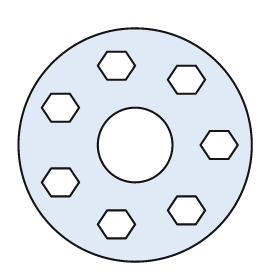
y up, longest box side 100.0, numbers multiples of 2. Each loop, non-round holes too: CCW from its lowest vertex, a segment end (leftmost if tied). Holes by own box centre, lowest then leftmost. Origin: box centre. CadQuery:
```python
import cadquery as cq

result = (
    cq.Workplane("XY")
    .moveTo(0.0, 0.0)
    .circle(50.0)
    .moveTo(-12.0, -40.0)
    .lineTo(-4.0, -40.0)
    .lineTo(0.0, -34.0)
    .lineTo(-4.0, -28.0)
    .lineTo(-12.0, -28.0)
    .lineTo(-16.0, -34.0)
    .close()
    .moveTo(18.0, -34.0)
    .lineTo(26.0, -34.0)
    .lineTo(30.0, -28.0)
    .lineTo(26.0, -22.0)
    .lineTo(18.0, -22.0)
    .lineTo(14.0, -28.0)
    .close()
    .moveTo(-36.0, -22.0)
    .lineTo(-28.0, -22.0)
    .lineTo(-24.0, -16.0)
    .lineTo(-28.0, -10.0)
    .lineTo(-36.0, -10.0)
    .lineTo(-40.0, -16.0)
    .close()
    .moveTo(0.0, 0.0)
    .circle(16.0)
    .moveTo(32.0, -6.0)
    .lineTo(40.0, -6.0)
    .lineTo(44.0, 0.0)
    .lineTo(40.0, 6.0)
    .lineTo(32.0, 6.0)
    .lineTo(28.0, 0.0)
    .close()
    .moveTo(-36.0, 10.0)
    .lineTo(-28.0, 10.0)
    .lineTo(-24.0, 16.0)
    .lineTo(-28.0, 22.0)
    .lineTo(-36.0, 22.0)
    .lineTo(-40.0, 16.0)
    .close()
    .moveTo(18.0, 22.0)
    .lineTo(26.0, 22.0)
    .lineTo(30.0, 28.0)
    .lineTo(26.0, 34.0)
    .lineTo(18.0, 34.0)
    .lineTo(14.0, 28.0)
    .close()
    .moveTo(-12.0, 28.0)
    .lineTo(-4.0, 28.0)
    .lineTo(0.0, 34.0)
    .lineTo(-4.0, 40.0)
    .lineTo(-12.0, 40.0)
    .lineTo(-16.0, 34.0)
    .close()
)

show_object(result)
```